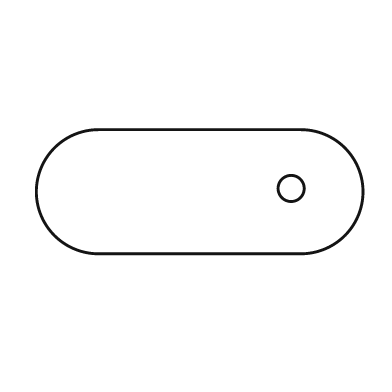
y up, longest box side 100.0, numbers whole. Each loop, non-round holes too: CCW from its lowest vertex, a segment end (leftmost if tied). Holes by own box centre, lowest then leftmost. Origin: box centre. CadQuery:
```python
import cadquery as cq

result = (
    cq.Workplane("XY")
    .moveTo(-31.0, -19.0)
    .lineTo(31.0, -19.0)
    .threePointArc((50.0, 0.0), (31.0, 19.0))
    .lineTo(-31.0, 19.0)
    .threePointArc((-50.0, 0.0), (-31.0, -19.0))
    .close()
    .moveTo(28.0, 1.0)
    .circle(4.0)
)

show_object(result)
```